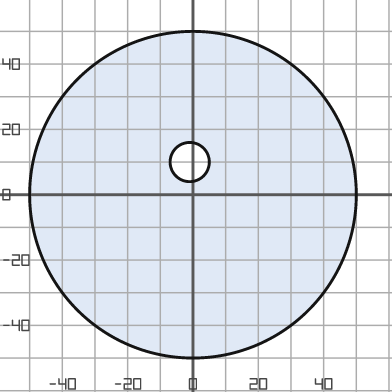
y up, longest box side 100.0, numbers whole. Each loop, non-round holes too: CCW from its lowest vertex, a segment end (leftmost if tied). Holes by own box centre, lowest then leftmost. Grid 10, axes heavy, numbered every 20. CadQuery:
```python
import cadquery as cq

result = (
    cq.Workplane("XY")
    .moveTo(0.0, 0.0)
    .circle(50.0)
    .moveTo(-1.0, 10.0)
    .circle(6.0)
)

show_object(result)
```